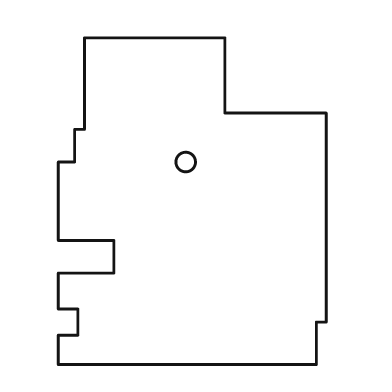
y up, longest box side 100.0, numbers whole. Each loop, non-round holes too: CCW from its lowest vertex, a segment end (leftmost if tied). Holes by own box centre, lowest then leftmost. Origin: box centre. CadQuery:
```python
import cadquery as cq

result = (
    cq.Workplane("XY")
    .moveTo(-41.0, -50.0)
    .lineTo(38.0, -50.0)
    .lineTo(38.0, -37.0)
    .lineTo(41.0, -37.0)
    .lineTo(41.0, 27.0)
    .lineTo(10.0, 27.0)
    .lineTo(10.0, 50.0)
    .lineTo(-33.0, 50.0)
    .lineTo(-33.0, 22.0)
    .lineTo(-36.0, 22.0)
    .lineTo(-36.0, 12.0)
    .lineTo(-41.0, 12.0)
    .lineTo(-41.0, -12.0)
    .lineTo(-24.0, -12.0)
    .lineTo(-24.0, -22.0)
    .lineTo(-41.0, -22.0)
    .lineTo(-41.0, -33.0)
    .lineTo(-35.0, -33.0)
    .lineTo(-35.0, -41.0)
    .lineTo(-41.0, -41.0)
    .close()
    .moveTo(-2.0, 12.0)
    .circle(3.0)
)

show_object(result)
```